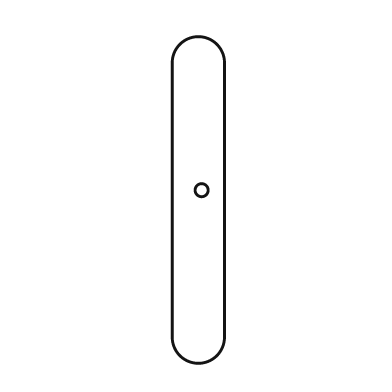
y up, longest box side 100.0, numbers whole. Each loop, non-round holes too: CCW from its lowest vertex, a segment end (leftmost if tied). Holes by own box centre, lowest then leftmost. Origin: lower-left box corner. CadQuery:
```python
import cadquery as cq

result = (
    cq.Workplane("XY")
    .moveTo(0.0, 8.0)
    .threePointArc((8.0, 0.0), (16.0, 8.0))
    .lineTo(16.0, 92.0)
    .threePointArc((8.0, 100.0), (0.0, 92.0))
    .close()
    .moveTo(9.0, 53.0)
    .circle(2.0)
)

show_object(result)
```